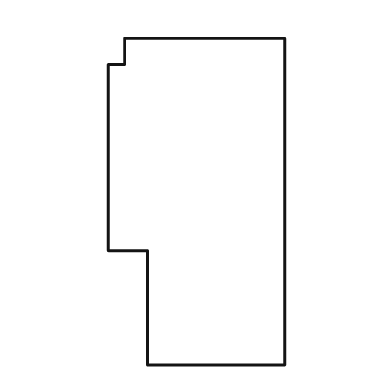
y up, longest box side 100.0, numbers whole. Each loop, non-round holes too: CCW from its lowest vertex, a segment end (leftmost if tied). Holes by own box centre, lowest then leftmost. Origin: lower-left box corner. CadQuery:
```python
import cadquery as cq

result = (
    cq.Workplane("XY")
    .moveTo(12.0, 0.0)
    .lineTo(54.0, 0.0)
    .lineTo(54.0, 100.0)
    .lineTo(5.0, 100.0)
    .lineTo(5.0, 92.0)
    .lineTo(0.0, 92.0)
    .lineTo(0.0, 35.0)
    .lineTo(12.0, 35.0)
    .close()
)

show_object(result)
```